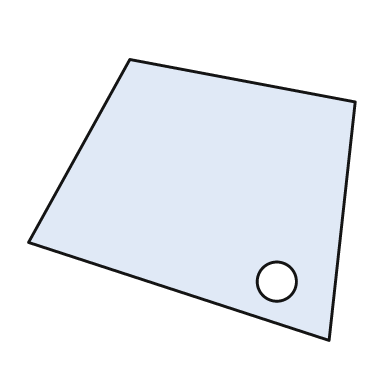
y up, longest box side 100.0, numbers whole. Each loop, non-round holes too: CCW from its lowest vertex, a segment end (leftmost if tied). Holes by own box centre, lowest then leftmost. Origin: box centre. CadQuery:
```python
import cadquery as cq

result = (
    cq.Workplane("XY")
    .moveTo(42.0, -43.0)
    .lineTo(50.0, 30.0)
    .lineTo(-19.0, 43.0)
    .lineTo(-50.0, -13.0)
    .close()
    .moveTo(26.0, -25.0)
    .circle(6.0)
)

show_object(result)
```